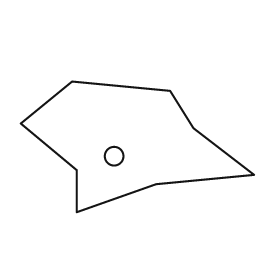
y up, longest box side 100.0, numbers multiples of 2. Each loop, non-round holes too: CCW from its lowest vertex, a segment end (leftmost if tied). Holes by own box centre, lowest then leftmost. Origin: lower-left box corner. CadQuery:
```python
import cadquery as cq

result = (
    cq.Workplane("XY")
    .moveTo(24.0, 0.0)
    .lineTo(58.0, 12.0)
    .lineTo(100.0, 16.0)
    .lineTo(74.0, 36.0)
    .lineTo(64.0, 52.0)
    .lineTo(22.0, 56.0)
    .lineTo(0.0, 38.0)
    .lineTo(24.0, 18.0)
    .close()
    .moveTo(40.0, 24.0)
    .circle(4.0)
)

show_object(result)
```